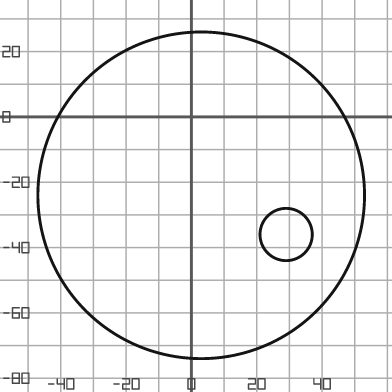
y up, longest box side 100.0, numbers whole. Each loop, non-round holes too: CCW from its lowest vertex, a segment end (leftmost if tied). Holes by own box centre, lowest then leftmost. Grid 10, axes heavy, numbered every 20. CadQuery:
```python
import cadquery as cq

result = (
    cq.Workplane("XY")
    .moveTo(3.0, -24.0)
    .circle(50.0)
    .moveTo(29.0, -36.0)
    .circle(8.0)
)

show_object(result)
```